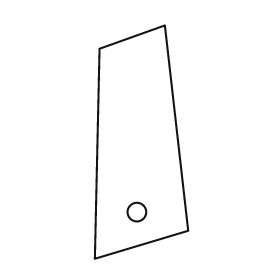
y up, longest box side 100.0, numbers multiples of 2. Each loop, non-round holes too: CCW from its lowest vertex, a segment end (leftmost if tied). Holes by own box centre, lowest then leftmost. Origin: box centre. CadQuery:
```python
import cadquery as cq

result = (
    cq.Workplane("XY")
    .moveTo(-20.0, -50.0)
    .lineTo(20.0, -38.0)
    .lineTo(10.0, 50.0)
    .lineTo(-18.0, 40.0)
    .close()
    .moveTo(-2.0, -30.0)
    .circle(4.0)
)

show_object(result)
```